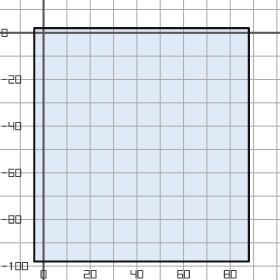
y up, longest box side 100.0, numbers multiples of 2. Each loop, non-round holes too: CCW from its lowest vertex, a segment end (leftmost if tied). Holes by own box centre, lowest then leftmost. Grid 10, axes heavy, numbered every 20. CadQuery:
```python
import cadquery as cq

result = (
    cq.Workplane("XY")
    .moveTo(-4.0, -98.0)
    .lineTo(88.0, -98.0)
    .lineTo(88.0, 2.0)
    .lineTo(-4.0, 2.0)
    .close()
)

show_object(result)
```